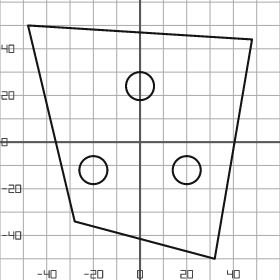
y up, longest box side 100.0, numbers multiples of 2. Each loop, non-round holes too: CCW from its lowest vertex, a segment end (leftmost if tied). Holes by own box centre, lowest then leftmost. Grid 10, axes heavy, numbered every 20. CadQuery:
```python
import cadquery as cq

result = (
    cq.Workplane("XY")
    .moveTo(32.0, -50.0)
    .lineTo(48.0, 44.0)
    .lineTo(-48.0, 50.0)
    .lineTo(-28.0, -34.0)
    .close()
    .moveTo(-20.0, -12.0)
    .circle(6.0)
    .moveTo(20.0, -12.0)
    .circle(6.0)
    .moveTo(0.0, 24.0)
    .circle(6.0)
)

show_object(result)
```